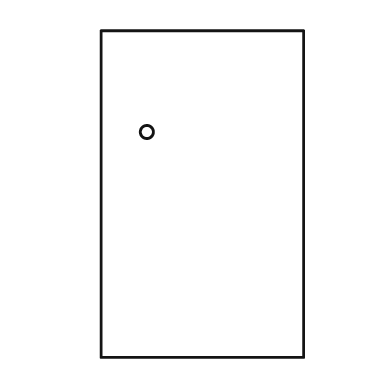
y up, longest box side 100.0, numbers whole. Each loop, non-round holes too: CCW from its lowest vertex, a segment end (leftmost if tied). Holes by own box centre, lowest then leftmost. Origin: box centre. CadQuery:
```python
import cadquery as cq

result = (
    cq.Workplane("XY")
    .moveTo(-31.0, -50.0)
    .lineTo(31.0, -50.0)
    .lineTo(31.0, 50.0)
    .lineTo(-31.0, 50.0)
    .close()
    .moveTo(-17.0, 19.0)
    .circle(2.0)
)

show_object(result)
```